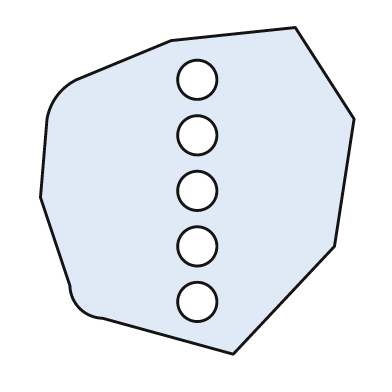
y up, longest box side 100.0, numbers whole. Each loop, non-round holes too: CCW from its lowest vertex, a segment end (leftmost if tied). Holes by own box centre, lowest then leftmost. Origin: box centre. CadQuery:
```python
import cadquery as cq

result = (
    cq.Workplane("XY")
    .moveTo(11.0, -50.0)
    .lineTo(42.0, -17.0)
    .lineTo(48.0, 22.0)
    .lineTo(30.0, 50.0)
    .lineTo(-8.0, 46.0)
    .lineTo(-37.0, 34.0)
    .threePointArc((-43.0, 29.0), (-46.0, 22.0))
    .lineTo(-48.0, -2.0)
    .lineTo(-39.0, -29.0)
    .threePointArc((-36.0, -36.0), (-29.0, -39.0))
    .close()
    .moveTo(0.0, -34.0)
    .circle(6.0)
    .moveTo(0.0, -17.0)
    .circle(6.0)
    .moveTo(0.0, 0.0)
    .circle(6.0)
    .moveTo(0.0, 17.0)
    .circle(6.0)
    .moveTo(0.0, 34.0)
    .circle(6.0)
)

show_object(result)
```